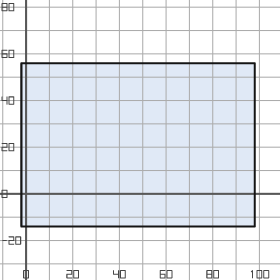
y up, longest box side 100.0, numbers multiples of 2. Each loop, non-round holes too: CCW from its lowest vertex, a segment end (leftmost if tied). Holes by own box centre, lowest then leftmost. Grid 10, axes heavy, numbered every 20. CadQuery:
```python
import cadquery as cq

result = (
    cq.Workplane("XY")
    .moveTo(-2.0, -14.0)
    .lineTo(98.0, -14.0)
    .lineTo(98.0, 56.0)
    .lineTo(-2.0, 56.0)
    .close()
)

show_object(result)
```